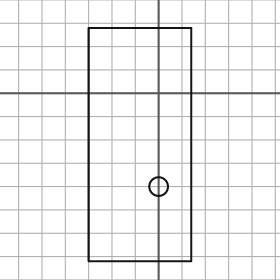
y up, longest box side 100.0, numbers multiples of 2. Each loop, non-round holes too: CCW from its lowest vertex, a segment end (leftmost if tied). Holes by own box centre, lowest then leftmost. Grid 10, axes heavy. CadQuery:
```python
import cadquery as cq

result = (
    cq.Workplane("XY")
    .moveTo(-30.0, -72.0)
    .lineTo(14.0, -72.0)
    .lineTo(14.0, 28.0)
    .lineTo(-30.0, 28.0)
    .close()
    .moveTo(0.0, -40.0)
    .circle(4.0)
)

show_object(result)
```